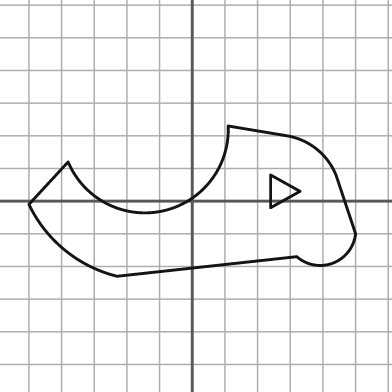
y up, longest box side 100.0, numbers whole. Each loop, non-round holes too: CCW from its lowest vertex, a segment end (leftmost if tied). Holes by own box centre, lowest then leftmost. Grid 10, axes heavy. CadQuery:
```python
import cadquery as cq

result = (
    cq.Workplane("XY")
    .moveTo(-23.0, -23.0)
    .lineTo(32.0, -17.0)
    .threePointArc((43.0, -19.0), (50.0, -10.0))
    .lineTo(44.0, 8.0)
    .threePointArc((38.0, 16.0), (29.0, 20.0))
    .lineTo(11.0, 23.0)
    .threePointArc((-9.0, -3.0), (-38.0, 12.0))
    .lineTo(-50.0, -1.0)
    .threePointArc((-39.0, -15.0), (-23.0, -23.0))
    .close()
    .moveTo(24.0, -2.0)
    .lineTo(33.0, 3.0)
    .lineTo(24.0, 8.0)
    .close()
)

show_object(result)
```